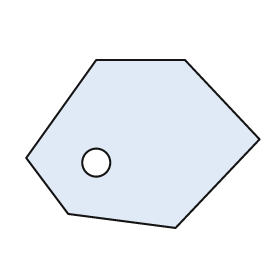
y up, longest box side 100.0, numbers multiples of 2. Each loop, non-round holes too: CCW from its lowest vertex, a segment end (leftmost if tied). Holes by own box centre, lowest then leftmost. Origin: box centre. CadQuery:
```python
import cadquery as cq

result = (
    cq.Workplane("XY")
    .moveTo(14.0, -36.0)
    .lineTo(50.0, 2.0)
    .lineTo(18.0, 36.0)
    .lineTo(-20.0, 36.0)
    .lineTo(-50.0, -6.0)
    .lineTo(-32.0, -30.0)
    .close()
    .moveTo(-20.0, -8.0)
    .circle(6.0)
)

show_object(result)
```